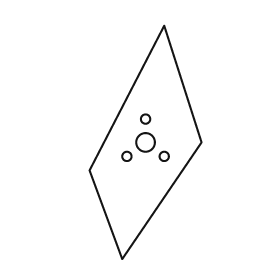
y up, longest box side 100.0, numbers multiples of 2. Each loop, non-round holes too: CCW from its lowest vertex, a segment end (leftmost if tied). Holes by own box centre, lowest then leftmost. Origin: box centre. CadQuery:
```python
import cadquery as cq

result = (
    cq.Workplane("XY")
    .moveTo(-10.0, -50.0)
    .lineTo(24.0, 0.0)
    .lineTo(8.0, 50.0)
    .lineTo(-24.0, -12.0)
    .close()
    .moveTo(-8.0, -6.0)
    .circle(2.0)
    .moveTo(8.0, -6.0)
    .circle(2.0)
    .moveTo(0.0, 0.0)
    .circle(4.0)
    .moveTo(0.0, 10.0)
    .circle(2.0)
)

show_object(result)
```